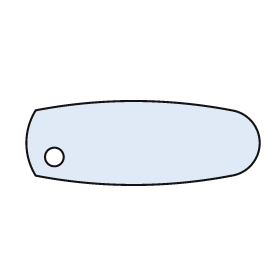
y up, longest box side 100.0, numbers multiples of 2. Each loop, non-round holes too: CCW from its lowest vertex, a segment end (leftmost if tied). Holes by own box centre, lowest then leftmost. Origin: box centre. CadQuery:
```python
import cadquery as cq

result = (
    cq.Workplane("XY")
    .moveTo(-46.0, -14.0)
    .threePointArc((-4.0, -18.0), (38.0, -14.0))
    .threePointArc((50.0, 0.0), (38.0, 14.0))
    .threePointArc((-4.0, 18.0), (-46.0, 14.0))
    .threePointArc((-50.0, 0.0), (-46.0, -14.0))
    .close()
    .moveTo(-38.0, -6.0)
    .circle(4.0)
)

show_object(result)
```